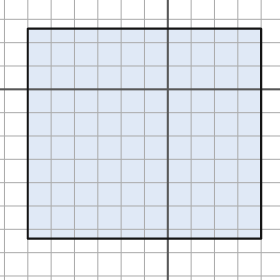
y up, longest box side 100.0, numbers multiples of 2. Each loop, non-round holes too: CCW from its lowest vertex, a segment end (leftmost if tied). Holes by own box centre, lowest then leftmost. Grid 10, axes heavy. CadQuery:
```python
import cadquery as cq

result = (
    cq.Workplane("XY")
    .moveTo(-60.0, -64.0)
    .lineTo(40.0, -64.0)
    .lineTo(40.0, 26.0)
    .lineTo(-60.0, 26.0)
    .close()
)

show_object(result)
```